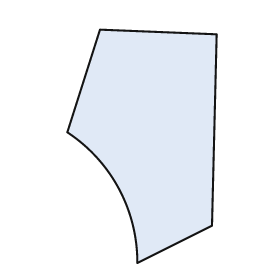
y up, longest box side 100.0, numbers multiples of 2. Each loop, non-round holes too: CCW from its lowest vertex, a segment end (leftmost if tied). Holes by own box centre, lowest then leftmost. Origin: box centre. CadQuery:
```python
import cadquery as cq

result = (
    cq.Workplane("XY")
    .moveTo(-2.0, -50.0)
    .lineTo(30.0, -34.0)
    .lineTo(32.0, 48.0)
    .lineTo(-18.0, 50.0)
    .lineTo(-32.0, 6.0)
    .threePointArc((-10.0, -18.0), (-2.0, -50.0))
    .close()
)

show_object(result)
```